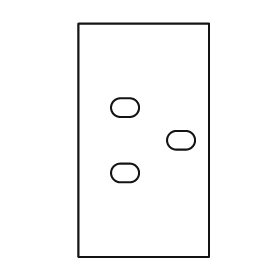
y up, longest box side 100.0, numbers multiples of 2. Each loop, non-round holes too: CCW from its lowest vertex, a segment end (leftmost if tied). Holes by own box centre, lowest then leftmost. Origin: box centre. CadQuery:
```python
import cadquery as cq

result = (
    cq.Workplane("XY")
    .moveTo(-28.0, -50.0)
    .lineTo(28.0, -50.0)
    .lineTo(28.0, 50.0)
    .lineTo(-28.0, 50.0)
    .close()
    .moveTo(-10.0, -18.0)
    .lineTo(-6.0, -18.0)
    .threePointArc((-2.0, -14.0), (-6.0, -10.0))
    .lineTo(-10.0, -10.0)
    .threePointArc((-14.0, -14.0), (-10.0, -18.0))
    .close()
    .moveTo(14.0, -4.0)
    .lineTo(18.0, -4.0)
    .threePointArc((22.0, 0.0), (18.0, 4.0))
    .lineTo(14.0, 4.0)
    .threePointArc((10.0, 0.0), (14.0, -4.0))
    .close()
    .moveTo(-10.0, 10.0)
    .lineTo(-6.0, 10.0)
    .threePointArc((-2.0, 14.0), (-6.0, 18.0))
    .lineTo(-10.0, 18.0)
    .threePointArc((-14.0, 14.0), (-10.0, 10.0))
    .close()
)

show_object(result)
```